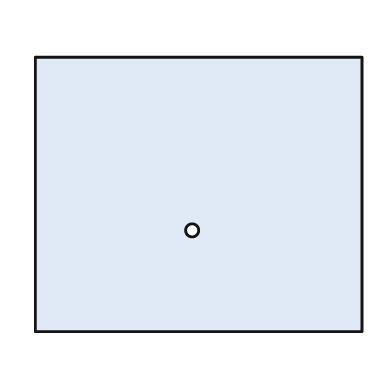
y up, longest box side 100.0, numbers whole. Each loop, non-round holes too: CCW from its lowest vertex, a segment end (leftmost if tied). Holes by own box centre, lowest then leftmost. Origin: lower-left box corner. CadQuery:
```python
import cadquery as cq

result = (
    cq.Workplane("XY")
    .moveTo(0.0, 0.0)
    .lineTo(100.0, 0.0)
    .lineTo(100.0, 84.0)
    .lineTo(0.0, 84.0)
    .close()
    .moveTo(48.0, 31.0)
    .circle(2.0)
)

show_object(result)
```